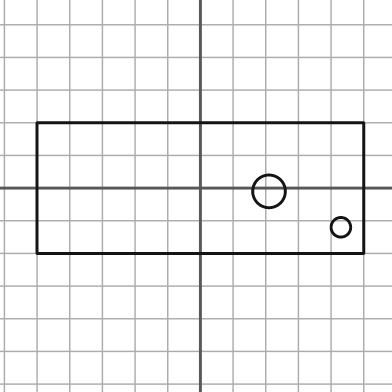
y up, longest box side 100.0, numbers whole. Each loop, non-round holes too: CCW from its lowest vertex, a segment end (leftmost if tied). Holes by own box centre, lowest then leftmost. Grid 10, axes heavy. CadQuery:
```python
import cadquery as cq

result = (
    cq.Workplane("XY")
    .moveTo(-50.0, -20.0)
    .lineTo(50.0, -20.0)
    .lineTo(50.0, 20.0)
    .lineTo(-50.0, 20.0)
    .close()
    .moveTo(43.0, -12.0)
    .circle(3.0)
    .moveTo(21.0, -1.0)
    .circle(5.0)
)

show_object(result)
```